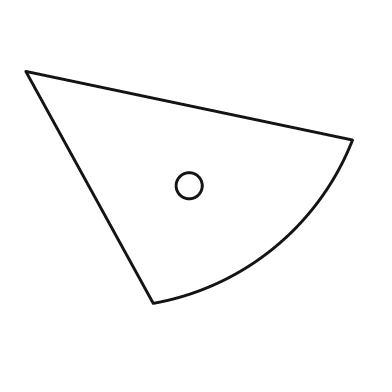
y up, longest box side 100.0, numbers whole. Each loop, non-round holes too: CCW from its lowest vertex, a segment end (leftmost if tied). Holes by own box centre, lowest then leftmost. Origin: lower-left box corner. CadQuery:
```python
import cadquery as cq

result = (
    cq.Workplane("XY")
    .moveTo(39.0, 0.0)
    .threePointArc((76.0, 17.0), (100.0, 50.0))
    .lineTo(0.0, 71.0)
    .close()
    .moveTo(50.0, 36.0)
    .circle(4.0)
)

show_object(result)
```